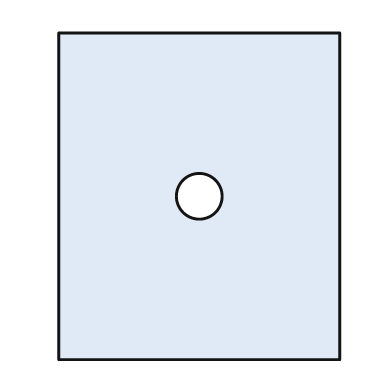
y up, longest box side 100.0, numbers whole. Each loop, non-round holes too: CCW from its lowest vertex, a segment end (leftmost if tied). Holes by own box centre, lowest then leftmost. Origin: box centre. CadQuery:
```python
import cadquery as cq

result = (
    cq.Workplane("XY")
    .moveTo(-43.0, -50.0)
    .lineTo(43.0, -50.0)
    .lineTo(43.0, 50.0)
    .lineTo(-43.0, 50.0)
    .close()
    .moveTo(0.0, 0.0)
    .circle(7.0)
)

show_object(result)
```